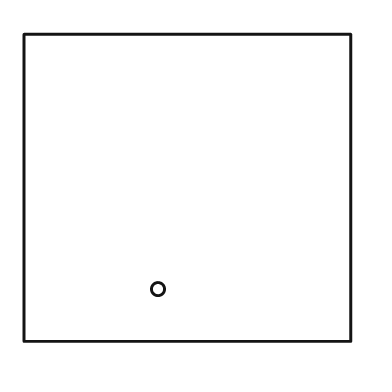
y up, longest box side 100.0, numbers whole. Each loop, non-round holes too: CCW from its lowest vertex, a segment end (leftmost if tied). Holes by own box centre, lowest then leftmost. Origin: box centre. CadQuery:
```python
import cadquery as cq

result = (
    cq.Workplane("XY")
    .moveTo(-50.0, -47.0)
    .lineTo(50.0, -47.0)
    .lineTo(50.0, 47.0)
    .lineTo(-50.0, 47.0)
    .close()
    .moveTo(-9.0, -31.0)
    .circle(2.0)
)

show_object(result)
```